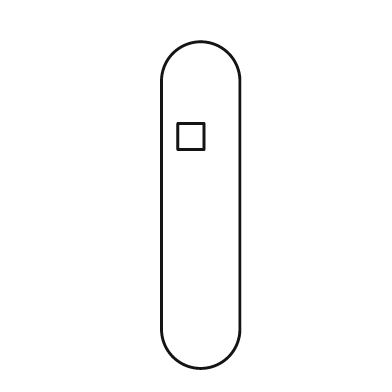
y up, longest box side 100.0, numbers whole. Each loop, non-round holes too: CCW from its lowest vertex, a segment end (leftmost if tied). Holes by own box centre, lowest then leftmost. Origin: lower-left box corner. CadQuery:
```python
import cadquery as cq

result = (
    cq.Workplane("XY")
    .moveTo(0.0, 12.0)
    .threePointArc((12.0, 0.0), (24.0, 12.0))
    .lineTo(24.0, 88.0)
    .threePointArc((12.0, 100.0), (0.0, 88.0))
    .close()
    .moveTo(5.0, 67.0)
    .lineTo(13.0, 67.0)
    .lineTo(13.0, 75.0)
    .lineTo(5.0, 75.0)
    .close()
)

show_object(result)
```